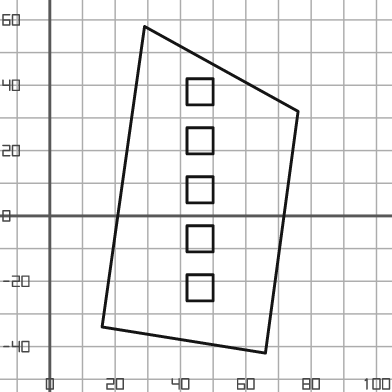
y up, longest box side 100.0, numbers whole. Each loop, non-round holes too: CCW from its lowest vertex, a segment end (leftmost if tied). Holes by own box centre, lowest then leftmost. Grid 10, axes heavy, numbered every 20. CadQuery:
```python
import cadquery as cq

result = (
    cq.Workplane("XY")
    .moveTo(66.0, -42.0)
    .lineTo(76.0, 32.0)
    .lineTo(29.0, 58.0)
    .lineTo(16.0, -34.0)
    .close()
    .moveTo(42.0, -26.0)
    .lineTo(50.0, -26.0)
    .lineTo(50.0, -18.0)
    .lineTo(42.0, -18.0)
    .close()
    .moveTo(42.0, -11.0)
    .lineTo(50.0, -11.0)
    .lineTo(50.0, -3.0)
    .lineTo(42.0, -3.0)
    .close()
    .moveTo(42.0, 4.0)
    .lineTo(50.0, 4.0)
    .lineTo(50.0, 12.0)
    .lineTo(42.0, 12.0)
    .close()
    .moveTo(42.0, 19.0)
    .lineTo(50.0, 19.0)
    .lineTo(50.0, 27.0)
    .lineTo(42.0, 27.0)
    .close()
    .moveTo(42.0, 34.0)
    .lineTo(50.0, 34.0)
    .lineTo(50.0, 42.0)
    .lineTo(42.0, 42.0)
    .close()
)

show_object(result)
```